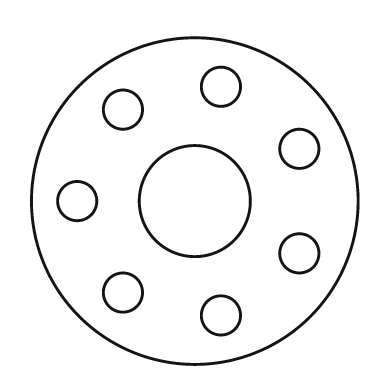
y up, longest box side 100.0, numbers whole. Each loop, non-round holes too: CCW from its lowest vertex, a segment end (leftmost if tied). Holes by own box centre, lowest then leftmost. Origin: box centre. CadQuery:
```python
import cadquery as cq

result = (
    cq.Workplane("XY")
    .moveTo(0.0, 0.0)
    .circle(50.0)
    .moveTo(8.0, -35.0)
    .circle(6.0)
    .moveTo(-22.0, -28.0)
    .circle(6.0)
    .moveTo(32.0, -16.0)
    .circle(6.0)
    .moveTo(-36.0, 0.0)
    .circle(6.0)
    .moveTo(0.0, 0.0)
    .circle(17.0)
    .moveTo(32.0, 16.0)
    .circle(6.0)
    .moveTo(-22.0, 28.0)
    .circle(6.0)
    .moveTo(8.0, 35.0)
    .circle(6.0)
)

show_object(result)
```